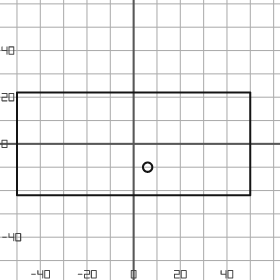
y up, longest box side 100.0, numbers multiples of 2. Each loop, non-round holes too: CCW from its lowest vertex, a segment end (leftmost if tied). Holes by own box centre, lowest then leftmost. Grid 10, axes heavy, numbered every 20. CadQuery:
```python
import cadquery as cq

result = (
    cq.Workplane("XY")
    .moveTo(-50.0, -22.0)
    .lineTo(50.0, -22.0)
    .lineTo(50.0, 22.0)
    .lineTo(-50.0, 22.0)
    .close()
    .moveTo(6.0, -10.0)
    .circle(2.0)
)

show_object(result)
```